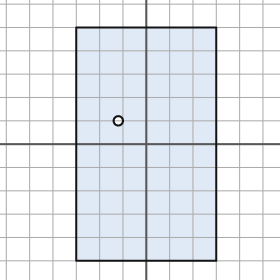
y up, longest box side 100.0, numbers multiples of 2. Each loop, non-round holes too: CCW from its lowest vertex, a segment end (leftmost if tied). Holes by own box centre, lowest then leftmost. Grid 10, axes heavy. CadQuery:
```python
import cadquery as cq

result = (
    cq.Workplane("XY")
    .moveTo(-30.0, -50.0)
    .lineTo(30.0, -50.0)
    .lineTo(30.0, 50.0)
    .lineTo(-30.0, 50.0)
    .close()
    .moveTo(-12.0, 10.0)
    .circle(2.0)
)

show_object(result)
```